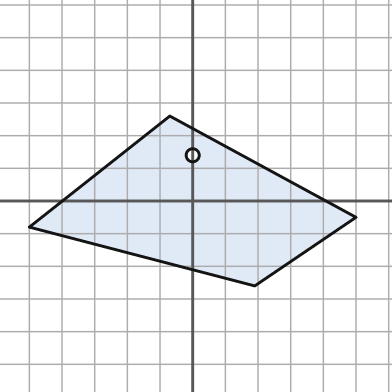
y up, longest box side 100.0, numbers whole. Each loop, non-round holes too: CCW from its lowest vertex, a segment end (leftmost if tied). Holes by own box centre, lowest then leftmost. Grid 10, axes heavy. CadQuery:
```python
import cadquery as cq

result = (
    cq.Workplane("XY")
    .moveTo(19.0, -26.0)
    .lineTo(50.0, -5.0)
    .lineTo(-7.0, 26.0)
    .lineTo(-50.0, -8.0)
    .close()
    .moveTo(0.0, 14.0)
    .circle(2.0)
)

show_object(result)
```